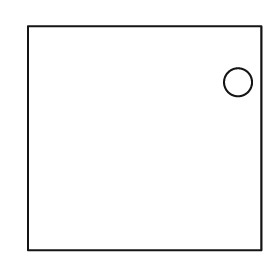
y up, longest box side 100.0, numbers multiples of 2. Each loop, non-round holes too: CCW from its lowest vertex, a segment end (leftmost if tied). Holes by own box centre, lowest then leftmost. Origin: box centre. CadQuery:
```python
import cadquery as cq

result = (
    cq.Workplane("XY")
    .moveTo(-50.0, -48.0)
    .lineTo(50.0, -48.0)
    .lineTo(50.0, 48.0)
    .lineTo(-50.0, 48.0)
    .close()
    .moveTo(40.0, 24.0)
    .circle(6.0)
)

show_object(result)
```